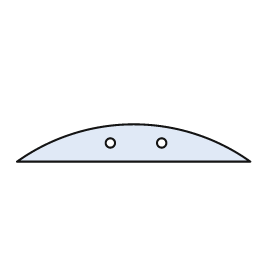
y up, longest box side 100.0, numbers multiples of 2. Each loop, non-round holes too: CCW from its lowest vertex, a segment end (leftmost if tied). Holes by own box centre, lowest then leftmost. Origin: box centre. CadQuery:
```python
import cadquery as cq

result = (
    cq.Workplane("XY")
    .moveTo(-50.0, -8.0)
    .lineTo(50.0, -8.0)
    .threePointArc((0.0, 8.0), (-50.0, -8.0))
    .close()
    .moveTo(-10.0, 0.0)
    .circle(2.0)
    .moveTo(12.0, 0.0)
    .circle(2.0)
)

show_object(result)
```